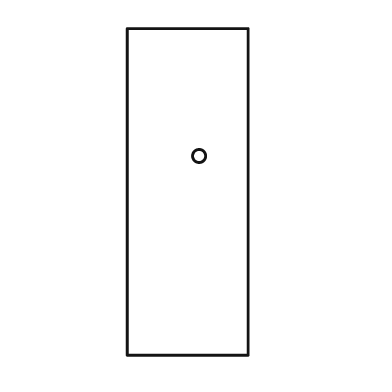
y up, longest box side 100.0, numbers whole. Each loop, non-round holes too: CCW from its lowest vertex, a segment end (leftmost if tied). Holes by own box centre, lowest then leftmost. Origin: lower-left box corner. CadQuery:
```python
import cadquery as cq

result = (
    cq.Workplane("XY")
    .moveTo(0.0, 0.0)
    .lineTo(37.0, 0.0)
    .lineTo(37.0, 100.0)
    .lineTo(0.0, 100.0)
    .close()
    .moveTo(22.0, 61.0)
    .circle(2.0)
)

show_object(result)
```